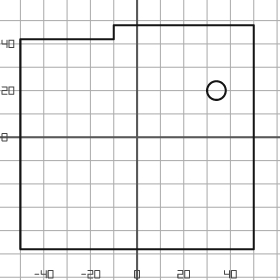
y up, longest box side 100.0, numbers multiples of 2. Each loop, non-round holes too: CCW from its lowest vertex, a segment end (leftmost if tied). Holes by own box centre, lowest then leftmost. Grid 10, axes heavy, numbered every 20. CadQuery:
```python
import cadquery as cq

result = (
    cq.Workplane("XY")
    .moveTo(-50.0, -48.0)
    .lineTo(50.0, -48.0)
    .lineTo(50.0, 48.0)
    .lineTo(-10.0, 48.0)
    .lineTo(-10.0, 42.0)
    .lineTo(-50.0, 42.0)
    .close()
    .moveTo(34.0, 20.0)
    .circle(4.0)
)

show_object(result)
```